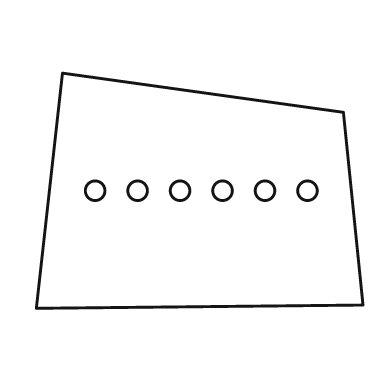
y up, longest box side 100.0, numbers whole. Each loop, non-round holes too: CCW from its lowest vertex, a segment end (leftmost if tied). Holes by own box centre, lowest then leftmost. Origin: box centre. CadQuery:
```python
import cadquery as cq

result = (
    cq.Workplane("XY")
    .moveTo(-50.0, -36.0)
    .lineTo(50.0, -35.0)
    .lineTo(44.0, 24.0)
    .lineTo(-42.0, 36.0)
    .close()
    .moveTo(-32.0, 0.0)
    .circle(3.0)
    .moveTo(-19.0, 0.0)
    .circle(3.0)
    .moveTo(-6.0, 0.0)
    .circle(3.0)
    .moveTo(7.0, 0.0)
    .circle(3.0)
    .moveTo(20.0, 0.0)
    .circle(3.0)
    .moveTo(33.0, 0.0)
    .circle(3.0)
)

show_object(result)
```